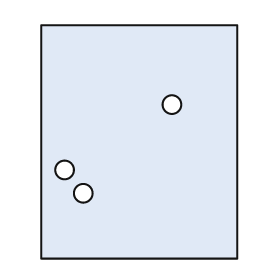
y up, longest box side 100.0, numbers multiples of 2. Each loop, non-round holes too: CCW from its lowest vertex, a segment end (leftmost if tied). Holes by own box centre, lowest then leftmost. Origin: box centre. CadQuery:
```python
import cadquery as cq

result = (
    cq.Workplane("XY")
    .moveTo(-42.0, -50.0)
    .lineTo(42.0, -50.0)
    .lineTo(42.0, 50.0)
    .lineTo(-42.0, 50.0)
    .close()
    .moveTo(-24.0, -22.0)
    .circle(4.0)
    .moveTo(-32.0, -12.0)
    .circle(4.0)
    .moveTo(14.0, 16.0)
    .circle(4.0)
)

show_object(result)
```